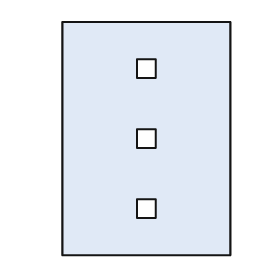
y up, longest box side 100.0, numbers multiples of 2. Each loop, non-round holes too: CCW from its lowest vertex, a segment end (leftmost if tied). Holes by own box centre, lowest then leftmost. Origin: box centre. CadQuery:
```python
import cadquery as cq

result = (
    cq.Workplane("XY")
    .moveTo(-36.0, -50.0)
    .lineTo(36.0, -50.0)
    .lineTo(36.0, 50.0)
    .lineTo(-36.0, 50.0)
    .close()
    .moveTo(-4.0, -34.0)
    .lineTo(4.0, -34.0)
    .lineTo(4.0, -26.0)
    .lineTo(-4.0, -26.0)
    .close()
    .moveTo(-4.0, -4.0)
    .lineTo(4.0, -4.0)
    .lineTo(4.0, 4.0)
    .lineTo(-4.0, 4.0)
    .close()
    .moveTo(-4.0, 26.0)
    .lineTo(4.0, 26.0)
    .lineTo(4.0, 34.0)
    .lineTo(-4.0, 34.0)
    .close()
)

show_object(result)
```